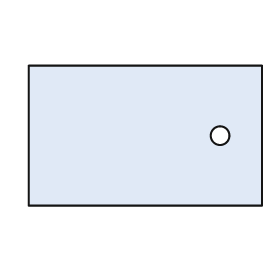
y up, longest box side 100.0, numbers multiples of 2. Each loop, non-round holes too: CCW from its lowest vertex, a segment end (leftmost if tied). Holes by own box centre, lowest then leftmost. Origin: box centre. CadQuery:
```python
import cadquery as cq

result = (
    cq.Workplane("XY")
    .moveTo(-50.0, -30.0)
    .lineTo(50.0, -30.0)
    .lineTo(50.0, 30.0)
    .lineTo(-50.0, 30.0)
    .close()
    .moveTo(32.0, 0.0)
    .circle(4.0)
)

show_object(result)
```